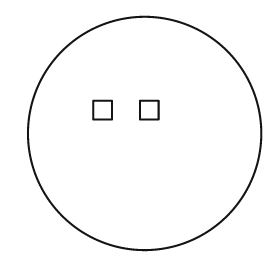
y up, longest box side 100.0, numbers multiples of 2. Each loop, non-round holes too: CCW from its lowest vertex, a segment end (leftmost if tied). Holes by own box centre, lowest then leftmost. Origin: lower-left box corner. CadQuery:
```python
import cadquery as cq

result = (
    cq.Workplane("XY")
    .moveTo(50.0, 50.0)
    .circle(50.0)
    .moveTo(28.0, 56.0)
    .lineTo(36.0, 56.0)
    .lineTo(36.0, 64.0)
    .lineTo(28.0, 64.0)
    .close()
    .moveTo(48.0, 56.0)
    .lineTo(56.0, 56.0)
    .lineTo(56.0, 64.0)
    .lineTo(48.0, 64.0)
    .close()
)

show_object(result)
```